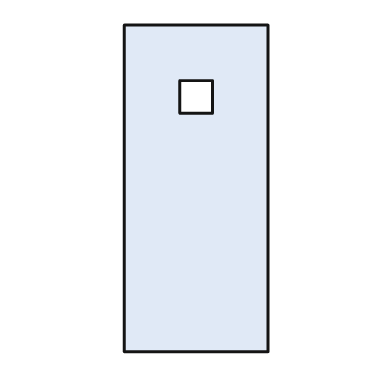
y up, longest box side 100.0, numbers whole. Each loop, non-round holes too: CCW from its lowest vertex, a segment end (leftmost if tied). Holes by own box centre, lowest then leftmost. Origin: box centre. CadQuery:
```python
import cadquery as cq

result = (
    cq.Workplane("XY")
    .moveTo(-22.0, -50.0)
    .lineTo(22.0, -50.0)
    .lineTo(22.0, 50.0)
    .lineTo(-22.0, 50.0)
    .close()
    .moveTo(-5.0, 23.0)
    .lineTo(5.0, 23.0)
    .lineTo(5.0, 33.0)
    .lineTo(-5.0, 33.0)
    .close()
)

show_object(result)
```